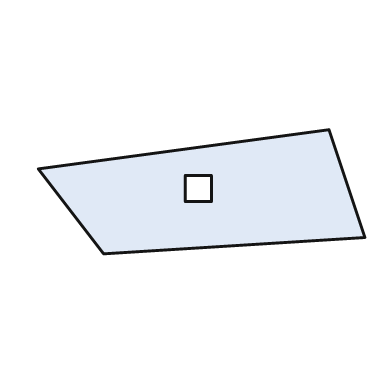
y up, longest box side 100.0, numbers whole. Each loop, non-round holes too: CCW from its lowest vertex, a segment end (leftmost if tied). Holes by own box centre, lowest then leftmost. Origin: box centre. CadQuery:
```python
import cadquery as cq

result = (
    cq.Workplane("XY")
    .moveTo(-30.0, -19.0)
    .lineTo(50.0, -14.0)
    .lineTo(39.0, 19.0)
    .lineTo(-50.0, 7.0)
    .close()
    .moveTo(-5.0, -3.0)
    .lineTo(3.0, -3.0)
    .lineTo(3.0, 5.0)
    .lineTo(-5.0, 5.0)
    .close()
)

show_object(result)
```